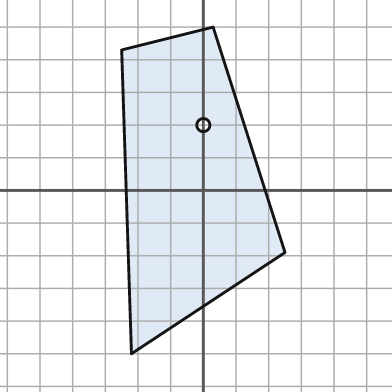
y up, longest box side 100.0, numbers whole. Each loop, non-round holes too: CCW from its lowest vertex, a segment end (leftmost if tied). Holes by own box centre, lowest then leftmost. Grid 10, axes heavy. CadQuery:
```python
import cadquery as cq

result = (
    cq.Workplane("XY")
    .moveTo(-22.0, -50.0)
    .lineTo(25.0, -19.0)
    .lineTo(3.0, 50.0)
    .lineTo(-25.0, 43.0)
    .close()
    .moveTo(0.0, 20.0)
    .circle(2.0)
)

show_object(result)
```